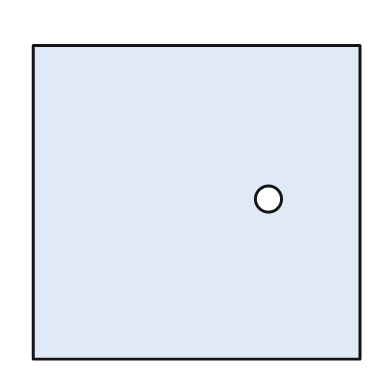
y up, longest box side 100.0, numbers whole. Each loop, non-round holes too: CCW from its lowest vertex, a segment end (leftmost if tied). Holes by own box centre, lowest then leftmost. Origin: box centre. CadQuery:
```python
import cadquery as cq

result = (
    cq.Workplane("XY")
    .moveTo(-50.0, -48.0)
    .lineTo(50.0, -48.0)
    .lineTo(50.0, 48.0)
    .lineTo(-50.0, 48.0)
    .close()
    .moveTo(22.0, 1.0)
    .circle(4.0)
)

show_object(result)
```